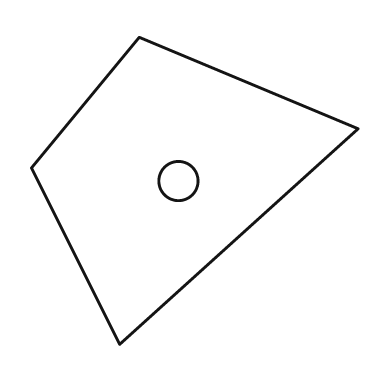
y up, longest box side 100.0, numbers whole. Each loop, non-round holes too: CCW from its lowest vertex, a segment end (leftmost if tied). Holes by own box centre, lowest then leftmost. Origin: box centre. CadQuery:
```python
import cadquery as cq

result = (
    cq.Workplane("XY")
    .moveTo(-23.0, -47.0)
    .lineTo(50.0, 19.0)
    .lineTo(-17.0, 47.0)
    .lineTo(-50.0, 7.0)
    .close()
    .moveTo(-5.0, 3.0)
    .circle(6.0)
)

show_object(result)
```